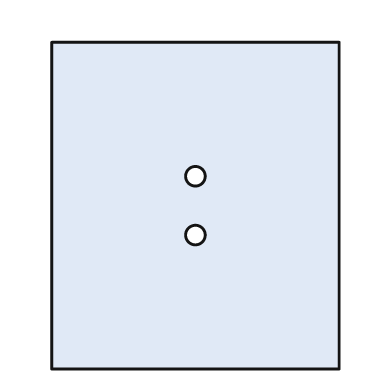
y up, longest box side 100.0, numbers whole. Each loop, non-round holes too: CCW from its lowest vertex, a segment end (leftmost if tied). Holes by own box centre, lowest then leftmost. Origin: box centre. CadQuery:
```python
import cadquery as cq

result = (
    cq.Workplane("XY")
    .moveTo(-44.0, -50.0)
    .lineTo(44.0, -50.0)
    .lineTo(44.0, 50.0)
    .lineTo(-44.0, 50.0)
    .close()
    .moveTo(0.0, -9.0)
    .circle(3.0)
    .moveTo(0.0, 9.0)
    .circle(3.0)
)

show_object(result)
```